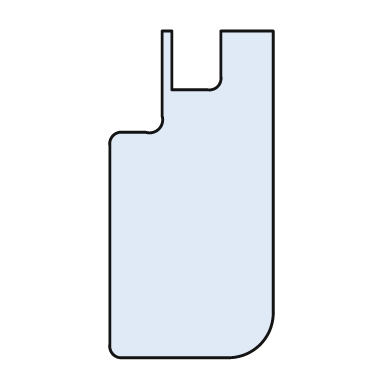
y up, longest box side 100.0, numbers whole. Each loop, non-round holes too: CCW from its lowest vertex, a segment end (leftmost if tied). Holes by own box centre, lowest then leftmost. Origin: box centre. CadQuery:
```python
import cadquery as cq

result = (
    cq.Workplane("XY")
    .moveTo(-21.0, -50.0)
    .lineTo(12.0, -50.0)
    .threePointArc((21.0, -46.0), (25.0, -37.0))
    .lineTo(25.0, 50.0)
    .lineTo(9.0, 50.0)
    .lineTo(9.0, 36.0)
    .threePointArc((8.0, 33.0), (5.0, 32.0))
    .lineTo(-6.0, 32.0)
    .lineTo(-6.0, 50.0)
    .lineTo(-9.0, 50.0)
    .lineTo(-9.0, 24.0)
    .threePointArc((-10.0, 20.0), (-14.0, 19.0))
    .lineTo(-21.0, 19.0)
    .threePointArc((-24.0, 18.0), (-25.0, 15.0))
    .lineTo(-25.0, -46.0)
    .threePointArc((-24.0, -49.0), (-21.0, -50.0))
    .close()
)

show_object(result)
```